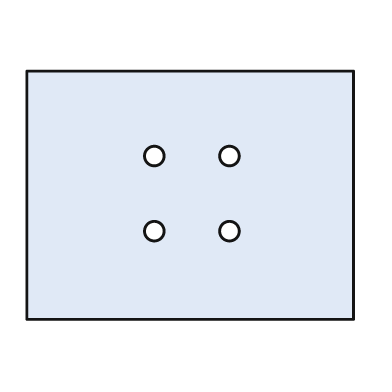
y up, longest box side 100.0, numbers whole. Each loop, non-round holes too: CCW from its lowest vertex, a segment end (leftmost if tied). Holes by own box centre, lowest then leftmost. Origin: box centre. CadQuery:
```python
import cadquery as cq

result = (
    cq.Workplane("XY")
    .moveTo(-50.0, -38.0)
    .lineTo(50.0, -38.0)
    .lineTo(50.0, 38.0)
    .lineTo(-50.0, 38.0)
    .close()
    .moveTo(-11.0, -11.0)
    .circle(3.0)
    .moveTo(12.0, -11.0)
    .circle(3.0)
    .moveTo(-11.0, 12.0)
    .circle(3.0)
    .moveTo(12.0, 12.0)
    .circle(3.0)
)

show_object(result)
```